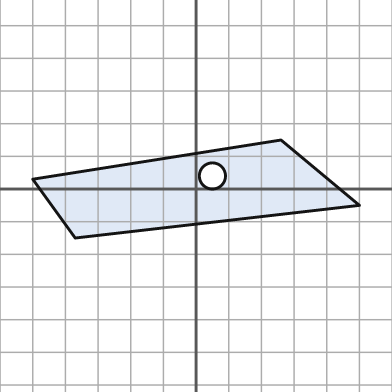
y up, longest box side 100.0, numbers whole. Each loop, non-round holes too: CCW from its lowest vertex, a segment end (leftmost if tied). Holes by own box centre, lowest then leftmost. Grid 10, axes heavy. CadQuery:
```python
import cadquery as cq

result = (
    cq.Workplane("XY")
    .moveTo(-37.0, -15.0)
    .lineTo(50.0, -5.0)
    .lineTo(26.0, 15.0)
    .lineTo(-50.0, 3.0)
    .close()
    .moveTo(5.0, 4.0)
    .circle(4.0)
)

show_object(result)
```